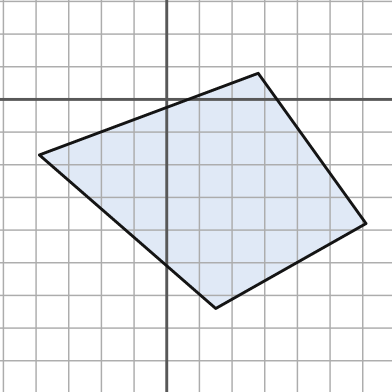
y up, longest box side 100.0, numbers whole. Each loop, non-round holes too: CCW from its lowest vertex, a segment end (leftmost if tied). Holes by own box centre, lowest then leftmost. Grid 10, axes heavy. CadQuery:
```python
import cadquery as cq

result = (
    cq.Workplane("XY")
    .moveTo(15.0, -64.0)
    .lineTo(61.0, -38.0)
    .lineTo(28.0, 8.0)
    .lineTo(-39.0, -17.0)
    .close()
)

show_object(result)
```